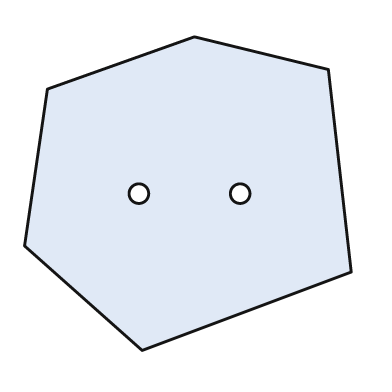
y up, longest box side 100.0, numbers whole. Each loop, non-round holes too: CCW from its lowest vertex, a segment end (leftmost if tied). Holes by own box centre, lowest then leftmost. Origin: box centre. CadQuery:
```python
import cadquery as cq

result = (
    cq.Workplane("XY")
    .moveTo(-14.0, -48.0)
    .lineTo(50.0, -24.0)
    .lineTo(43.0, 38.0)
    .lineTo(2.0, 48.0)
    .lineTo(-43.0, 32.0)
    .lineTo(-50.0, -16.0)
    .close()
    .moveTo(-15.0, 0.0)
    .circle(3.0)
    .moveTo(16.0, 0.0)
    .circle(3.0)
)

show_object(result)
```